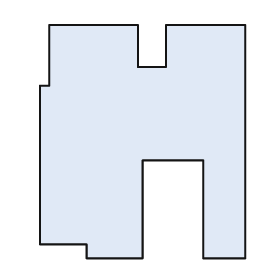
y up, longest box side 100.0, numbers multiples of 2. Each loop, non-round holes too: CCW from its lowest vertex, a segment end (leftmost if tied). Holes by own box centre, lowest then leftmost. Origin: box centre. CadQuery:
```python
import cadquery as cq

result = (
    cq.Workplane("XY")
    .moveTo(-24.0, -50.0)
    .lineTo(0.0, -50.0)
    .lineTo(0.0, -8.0)
    .lineTo(26.0, -8.0)
    .lineTo(26.0, -50.0)
    .lineTo(44.0, -50.0)
    .lineTo(44.0, 50.0)
    .lineTo(10.0, 50.0)
    .lineTo(10.0, 32.0)
    .lineTo(-2.0, 32.0)
    .lineTo(-2.0, 50.0)
    .lineTo(-40.0, 50.0)
    .lineTo(-40.0, 24.0)
    .lineTo(-44.0, 24.0)
    .lineTo(-44.0, -44.0)
    .lineTo(-24.0, -44.0)
    .close()
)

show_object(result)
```